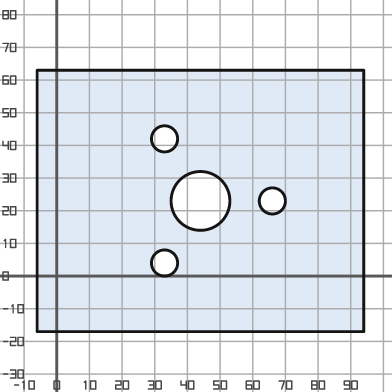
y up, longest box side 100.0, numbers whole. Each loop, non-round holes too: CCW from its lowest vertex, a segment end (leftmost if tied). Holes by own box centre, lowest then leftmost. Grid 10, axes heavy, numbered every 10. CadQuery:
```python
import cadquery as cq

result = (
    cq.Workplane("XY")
    .moveTo(-6.0, -17.0)
    .lineTo(94.0, -17.0)
    .lineTo(94.0, 63.0)
    .lineTo(-6.0, 63.0)
    .close()
    .moveTo(33.0, 4.0)
    .circle(4.0)
    .moveTo(44.0, 23.0)
    .circle(9.0)
    .moveTo(66.0, 23.0)
    .circle(4.0)
    .moveTo(33.0, 42.0)
    .circle(4.0)
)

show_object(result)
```